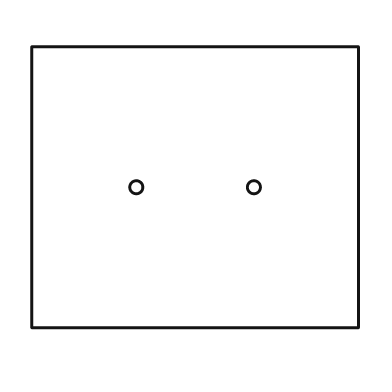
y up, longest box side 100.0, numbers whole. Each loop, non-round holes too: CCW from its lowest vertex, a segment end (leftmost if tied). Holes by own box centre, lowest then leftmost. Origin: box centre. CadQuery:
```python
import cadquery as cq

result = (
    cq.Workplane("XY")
    .moveTo(-50.0, -43.0)
    .lineTo(50.0, -43.0)
    .lineTo(50.0, 43.0)
    .lineTo(-50.0, 43.0)
    .close()
    .moveTo(-18.0, 0.0)
    .circle(2.0)
    .moveTo(18.0, 0.0)
    .circle(2.0)
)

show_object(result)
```